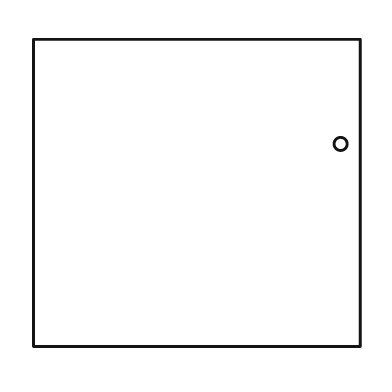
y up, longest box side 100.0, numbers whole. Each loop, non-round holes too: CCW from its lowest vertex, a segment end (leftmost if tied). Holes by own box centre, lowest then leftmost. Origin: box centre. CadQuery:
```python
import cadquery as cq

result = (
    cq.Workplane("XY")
    .moveTo(-50.0, -47.0)
    .lineTo(50.0, -47.0)
    .lineTo(50.0, 47.0)
    .lineTo(-50.0, 47.0)
    .close()
    .moveTo(44.0, 15.0)
    .circle(2.0)
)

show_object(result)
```